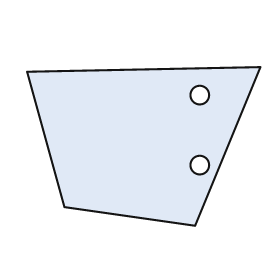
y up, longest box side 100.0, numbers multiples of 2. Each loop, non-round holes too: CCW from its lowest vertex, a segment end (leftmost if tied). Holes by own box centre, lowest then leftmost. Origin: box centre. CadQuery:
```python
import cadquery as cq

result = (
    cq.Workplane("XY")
    .moveTo(22.0, -34.0)
    .lineTo(50.0, 34.0)
    .lineTo(-50.0, 32.0)
    .lineTo(-34.0, -26.0)
    .close()
    .moveTo(24.0, -8.0)
    .circle(4.0)
    .moveTo(24.0, 22.0)
    .circle(4.0)
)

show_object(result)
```